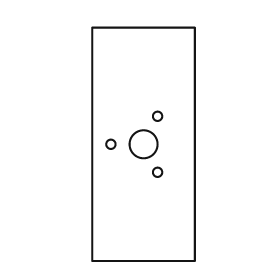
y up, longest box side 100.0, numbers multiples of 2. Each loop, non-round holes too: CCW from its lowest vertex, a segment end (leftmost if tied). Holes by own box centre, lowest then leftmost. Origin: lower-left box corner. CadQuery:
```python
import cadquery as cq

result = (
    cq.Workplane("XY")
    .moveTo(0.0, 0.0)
    .lineTo(44.0, 0.0)
    .lineTo(44.0, 100.0)
    .lineTo(0.0, 100.0)
    .close()
    .moveTo(28.0, 38.0)
    .circle(2.0)
    .moveTo(8.0, 50.0)
    .circle(2.0)
    .moveTo(22.0, 50.0)
    .circle(6.0)
    .moveTo(28.0, 62.0)
    .circle(2.0)
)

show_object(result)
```